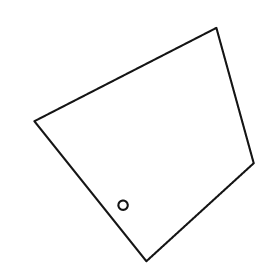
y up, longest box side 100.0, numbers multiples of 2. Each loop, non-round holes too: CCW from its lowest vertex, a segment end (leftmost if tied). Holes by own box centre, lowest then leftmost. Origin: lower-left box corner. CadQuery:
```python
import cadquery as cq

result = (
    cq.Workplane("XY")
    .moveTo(48.0, 0.0)
    .lineTo(94.0, 42.0)
    .lineTo(78.0, 100.0)
    .lineTo(0.0, 60.0)
    .close()
    .moveTo(38.0, 24.0)
    .circle(2.0)
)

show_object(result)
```